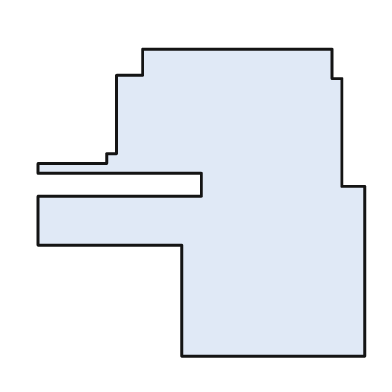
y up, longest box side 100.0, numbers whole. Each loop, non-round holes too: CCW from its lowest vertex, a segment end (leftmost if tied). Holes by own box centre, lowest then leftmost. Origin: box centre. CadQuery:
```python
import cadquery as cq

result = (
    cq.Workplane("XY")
    .moveTo(-6.0, -47.0)
    .lineTo(50.0, -47.0)
    .lineTo(50.0, 5.0)
    .lineTo(43.0, 5.0)
    .lineTo(43.0, 38.0)
    .lineTo(40.0, 38.0)
    .lineTo(40.0, 47.0)
    .lineTo(-18.0, 47.0)
    .lineTo(-18.0, 39.0)
    .lineTo(-26.0, 39.0)
    .lineTo(-26.0, 15.0)
    .lineTo(-29.0, 15.0)
    .lineTo(-29.0, 12.0)
    .lineTo(-50.0, 12.0)
    .lineTo(-50.0, 9.0)
    .lineTo(0.0, 9.0)
    .lineTo(0.0, 2.0)
    .lineTo(-50.0, 2.0)
    .lineTo(-50.0, -13.0)
    .lineTo(-6.0, -13.0)
    .close()
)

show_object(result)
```